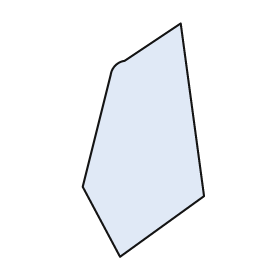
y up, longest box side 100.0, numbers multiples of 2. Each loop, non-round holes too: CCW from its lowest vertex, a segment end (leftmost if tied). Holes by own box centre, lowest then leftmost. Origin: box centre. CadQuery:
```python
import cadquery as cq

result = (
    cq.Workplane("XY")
    .moveTo(-10.0, -50.0)
    .lineTo(26.0, -24.0)
    .lineTo(16.0, 50.0)
    .lineTo(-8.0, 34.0)
    .threePointArc((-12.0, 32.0), (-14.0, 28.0))
    .lineTo(-26.0, -20.0)
    .close()
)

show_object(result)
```